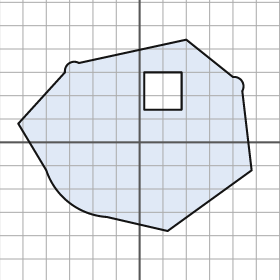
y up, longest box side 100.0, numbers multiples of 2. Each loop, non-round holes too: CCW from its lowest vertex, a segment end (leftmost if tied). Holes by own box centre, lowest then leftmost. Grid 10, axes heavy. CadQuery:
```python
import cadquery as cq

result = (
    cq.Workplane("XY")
    .moveTo(12.0, -38.0)
    .lineTo(48.0, -12.0)
    .lineTo(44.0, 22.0)
    .threePointArc((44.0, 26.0), (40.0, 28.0))
    .lineTo(20.0, 44.0)
    .lineTo(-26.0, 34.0)
    .threePointArc((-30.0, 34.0), (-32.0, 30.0))
    .lineTo(-52.0, 8.0)
    .lineTo(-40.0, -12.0)
    .threePointArc((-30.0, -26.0), (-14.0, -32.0))
    .close()
    .moveTo(2.0, 14.0)
    .lineTo(18.0, 14.0)
    .lineTo(18.0, 30.0)
    .lineTo(2.0, 30.0)
    .close()
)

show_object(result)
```